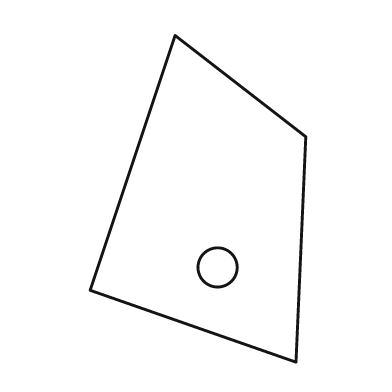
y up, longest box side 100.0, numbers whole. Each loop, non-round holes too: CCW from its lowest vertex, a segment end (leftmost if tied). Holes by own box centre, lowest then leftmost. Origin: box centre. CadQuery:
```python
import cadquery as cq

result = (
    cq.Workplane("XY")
    .moveTo(30.0, -50.0)
    .lineTo(33.0, 19.0)
    .lineTo(-7.0, 50.0)
    .lineTo(-33.0, -28.0)
    .close()
    .moveTo(6.0, -21.0)
    .circle(6.0)
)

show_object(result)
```